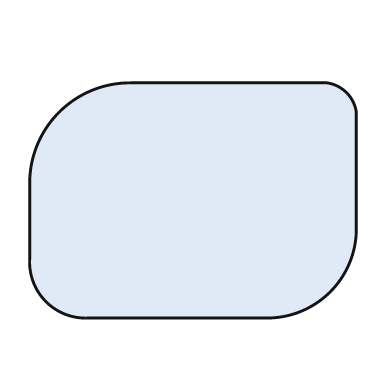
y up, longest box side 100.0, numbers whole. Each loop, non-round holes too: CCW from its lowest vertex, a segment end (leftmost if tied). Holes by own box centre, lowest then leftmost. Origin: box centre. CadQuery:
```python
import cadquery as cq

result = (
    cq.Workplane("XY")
    .moveTo(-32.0, -36.0)
    .lineTo(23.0, -36.0)
    .threePointArc((42.0, -28.0), (50.0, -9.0))
    .lineTo(50.0, 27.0)
    .threePointArc((47.0, 33.0), (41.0, 36.0))
    .lineTo(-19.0, 36.0)
    .threePointArc((-41.0, 27.0), (-50.0, 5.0))
    .lineTo(-50.0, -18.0)
    .threePointArc((-45.0, -31.0), (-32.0, -36.0))
    .close()
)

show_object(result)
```